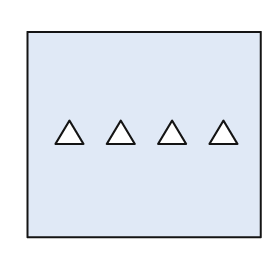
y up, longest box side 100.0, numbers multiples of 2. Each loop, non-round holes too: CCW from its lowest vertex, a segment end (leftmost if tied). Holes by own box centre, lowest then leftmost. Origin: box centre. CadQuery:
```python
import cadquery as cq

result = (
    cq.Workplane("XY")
    .moveTo(-50.0, -44.0)
    .lineTo(50.0, -44.0)
    .lineTo(50.0, 44.0)
    .lineTo(-50.0, 44.0)
    .close()
    .moveTo(-38.0, -4.0)
    .lineTo(-26.0, -4.0)
    .lineTo(-32.0, 6.0)
    .close()
    .moveTo(-16.0, -4.0)
    .lineTo(-4.0, -4.0)
    .lineTo(-10.0, 6.0)
    .close()
    .moveTo(6.0, -4.0)
    .lineTo(18.0, -4.0)
    .lineTo(12.0, 6.0)
    .close()
    .moveTo(28.0, -4.0)
    .lineTo(40.0, -4.0)
    .lineTo(34.0, 6.0)
    .close()
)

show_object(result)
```